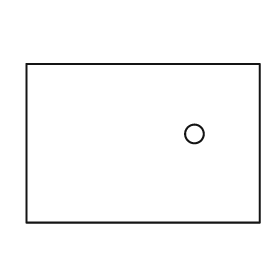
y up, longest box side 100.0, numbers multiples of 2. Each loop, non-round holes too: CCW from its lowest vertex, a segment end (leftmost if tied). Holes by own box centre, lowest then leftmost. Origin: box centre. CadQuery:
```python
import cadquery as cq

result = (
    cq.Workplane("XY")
    .moveTo(-50.0, -34.0)
    .lineTo(50.0, -34.0)
    .lineTo(50.0, 34.0)
    .lineTo(-50.0, 34.0)
    .close()
    .moveTo(22.0, 4.0)
    .circle(4.0)
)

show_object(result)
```